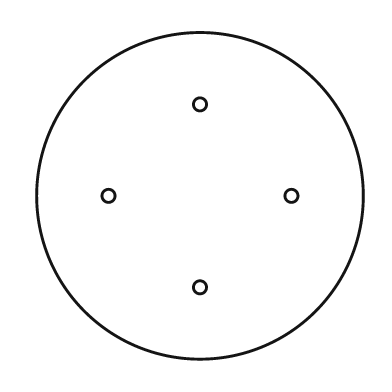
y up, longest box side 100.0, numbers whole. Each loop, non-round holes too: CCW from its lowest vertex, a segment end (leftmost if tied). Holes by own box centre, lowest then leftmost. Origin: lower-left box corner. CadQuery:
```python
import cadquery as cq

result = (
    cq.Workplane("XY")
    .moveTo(50.0, 50.0)
    .circle(50.0)
    .moveTo(50.0, 22.0)
    .circle(2.0)
    .moveTo(22.0, 50.0)
    .circle(2.0)
    .moveTo(78.0, 50.0)
    .circle(2.0)
    .moveTo(50.0, 78.0)
    .circle(2.0)
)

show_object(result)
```